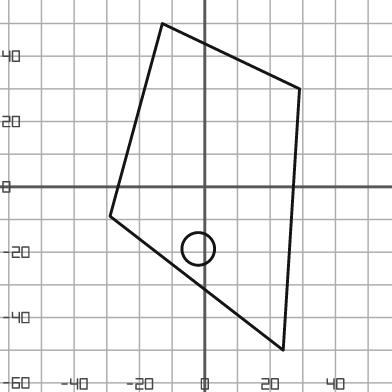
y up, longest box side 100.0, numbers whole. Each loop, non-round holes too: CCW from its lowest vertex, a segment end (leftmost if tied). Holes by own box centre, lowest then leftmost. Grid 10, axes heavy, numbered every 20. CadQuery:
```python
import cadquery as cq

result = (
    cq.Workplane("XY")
    .moveTo(24.0, -50.0)
    .lineTo(29.0, 30.0)
    .lineTo(-13.0, 50.0)
    .lineTo(-29.0, -9.0)
    .close()
    .moveTo(-2.0, -19.0)
    .circle(5.0)
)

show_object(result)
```